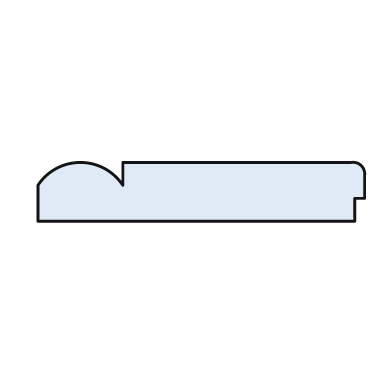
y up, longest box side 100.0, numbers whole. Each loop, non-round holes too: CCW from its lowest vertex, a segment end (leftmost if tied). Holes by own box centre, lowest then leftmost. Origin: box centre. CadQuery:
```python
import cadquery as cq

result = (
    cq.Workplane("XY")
    .moveTo(-50.0, -9.0)
    .lineTo(47.0, -9.0)
    .lineTo(47.0, -2.0)
    .lineTo(50.0, -2.0)
    .lineTo(50.0, 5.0)
    .threePointArc((49.0, 8.0), (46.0, 9.0))
    .lineTo(-24.0, 9.0)
    .lineTo(-24.0, 2.0)
    .threePointArc((-37.0, 9.0), (-50.0, 2.0))
    .close()
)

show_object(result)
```